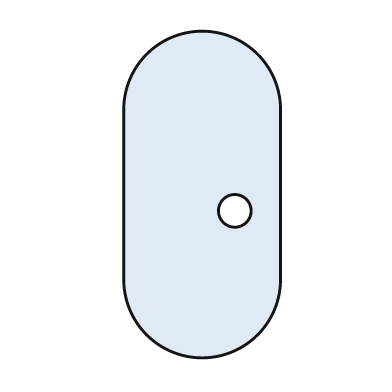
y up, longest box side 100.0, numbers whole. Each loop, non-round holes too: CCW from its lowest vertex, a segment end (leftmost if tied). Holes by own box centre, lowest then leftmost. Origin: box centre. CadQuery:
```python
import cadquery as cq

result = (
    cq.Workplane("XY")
    .moveTo(-24.0, -26.0)
    .threePointArc((0.0, -50.0), (24.0, -26.0))
    .lineTo(24.0, 26.0)
    .threePointArc((0.0, 50.0), (-24.0, 26.0))
    .close()
    .moveTo(10.0, -5.0)
    .circle(5.0)
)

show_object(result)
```